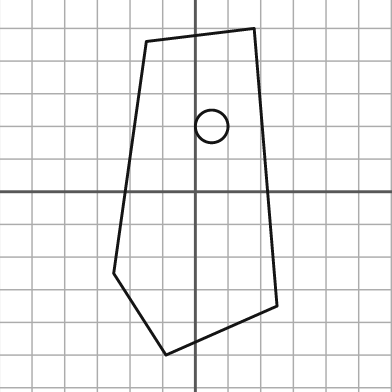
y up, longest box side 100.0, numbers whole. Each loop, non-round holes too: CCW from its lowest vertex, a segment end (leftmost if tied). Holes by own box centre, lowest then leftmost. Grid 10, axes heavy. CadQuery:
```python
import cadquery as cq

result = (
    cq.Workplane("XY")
    .moveTo(-9.0, -50.0)
    .lineTo(25.0, -35.0)
    .lineTo(18.0, 50.0)
    .lineTo(-15.0, 46.0)
    .lineTo(-25.0, -25.0)
    .close()
    .moveTo(5.0, 20.0)
    .circle(5.0)
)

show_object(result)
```